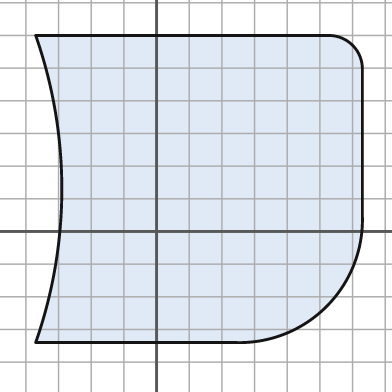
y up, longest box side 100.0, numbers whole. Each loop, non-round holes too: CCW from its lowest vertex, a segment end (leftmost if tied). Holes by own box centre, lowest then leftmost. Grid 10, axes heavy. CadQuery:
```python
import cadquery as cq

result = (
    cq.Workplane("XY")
    .moveTo(-37.0, -34.0)
    .lineTo(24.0, -34.0)
    .threePointArc((52.0, -23.0), (63.0, 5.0))
    .lineTo(63.0, 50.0)
    .threePointArc((60.0, 57.0), (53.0, 60.0))
    .lineTo(-37.0, 60.0)
    .threePointArc((-29.0, 13.0), (-37.0, -34.0))
    .close()
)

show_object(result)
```